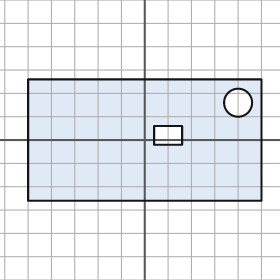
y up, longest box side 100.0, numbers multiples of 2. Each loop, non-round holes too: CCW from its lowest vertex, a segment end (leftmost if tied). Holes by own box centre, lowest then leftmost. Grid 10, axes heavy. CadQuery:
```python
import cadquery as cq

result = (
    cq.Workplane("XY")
    .moveTo(-50.0, -26.0)
    .lineTo(50.0, -26.0)
    .lineTo(50.0, 26.0)
    .lineTo(-50.0, 26.0)
    .close()
    .moveTo(4.0, -2.0)
    .lineTo(16.0, -2.0)
    .lineTo(16.0, 6.0)
    .lineTo(4.0, 6.0)
    .close()
    .moveTo(40.0, 16.0)
    .circle(6.0)
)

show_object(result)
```